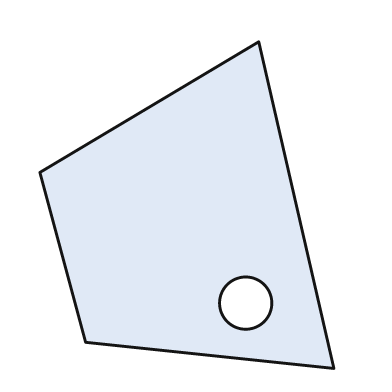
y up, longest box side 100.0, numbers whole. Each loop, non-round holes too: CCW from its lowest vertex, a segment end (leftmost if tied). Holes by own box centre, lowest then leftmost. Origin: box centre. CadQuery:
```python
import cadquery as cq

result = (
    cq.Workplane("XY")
    .moveTo(45.0, -50.0)
    .lineTo(22.0, 50.0)
    .lineTo(-45.0, 10.0)
    .lineTo(-31.0, -42.0)
    .close()
    .moveTo(18.0, -30.0)
    .circle(8.0)
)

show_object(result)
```